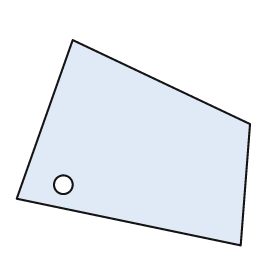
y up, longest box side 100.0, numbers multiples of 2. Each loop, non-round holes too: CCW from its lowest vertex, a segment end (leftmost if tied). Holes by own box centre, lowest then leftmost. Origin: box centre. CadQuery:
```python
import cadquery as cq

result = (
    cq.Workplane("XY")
    .moveTo(46.0, -44.0)
    .lineTo(50.0, 8.0)
    .lineTo(-26.0, 44.0)
    .lineTo(-50.0, -24.0)
    .close()
    .moveTo(-30.0, -18.0)
    .circle(4.0)
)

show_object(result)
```